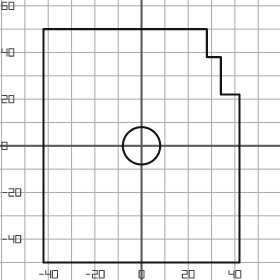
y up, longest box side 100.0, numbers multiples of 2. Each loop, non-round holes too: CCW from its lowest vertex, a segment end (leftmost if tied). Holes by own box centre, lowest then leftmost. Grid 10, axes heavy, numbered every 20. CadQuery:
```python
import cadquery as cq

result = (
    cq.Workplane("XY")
    .moveTo(-42.0, -50.0)
    .lineTo(42.0, -50.0)
    .lineTo(42.0, 22.0)
    .lineTo(34.0, 22.0)
    .lineTo(34.0, 38.0)
    .lineTo(28.0, 38.0)
    .lineTo(28.0, 50.0)
    .lineTo(-42.0, 50.0)
    .close()
    .moveTo(0.0, 0.0)
    .circle(8.0)
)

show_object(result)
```